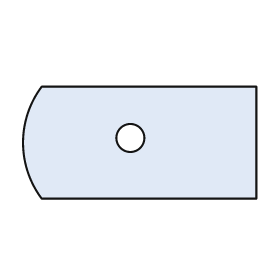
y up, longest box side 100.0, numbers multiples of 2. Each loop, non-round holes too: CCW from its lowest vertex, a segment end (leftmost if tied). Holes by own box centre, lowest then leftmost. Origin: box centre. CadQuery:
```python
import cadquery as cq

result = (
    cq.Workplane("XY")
    .moveTo(-42.0, -24.0)
    .lineTo(50.0, -24.0)
    .lineTo(50.0, 24.0)
    .lineTo(-42.0, 24.0)
    .threePointArc((-50.0, 0.0), (-42.0, -24.0))
    .close()
    .moveTo(-4.0, 2.0)
    .circle(6.0)
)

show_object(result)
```